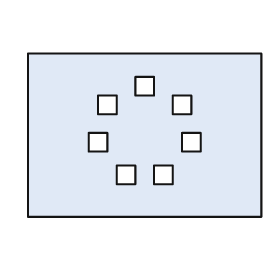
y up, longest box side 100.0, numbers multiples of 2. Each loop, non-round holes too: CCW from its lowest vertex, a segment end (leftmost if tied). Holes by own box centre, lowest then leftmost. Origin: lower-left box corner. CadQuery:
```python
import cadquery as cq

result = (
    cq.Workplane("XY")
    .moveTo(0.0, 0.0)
    .lineTo(100.0, 0.0)
    .lineTo(100.0, 70.0)
    .lineTo(0.0, 70.0)
    .close()
    .moveTo(38.0, 14.0)
    .lineTo(46.0, 14.0)
    .lineTo(46.0, 22.0)
    .lineTo(38.0, 22.0)
    .close()
    .moveTo(54.0, 14.0)
    .lineTo(62.0, 14.0)
    .lineTo(62.0, 22.0)
    .lineTo(54.0, 22.0)
    .close()
    .moveTo(26.0, 28.0)
    .lineTo(34.0, 28.0)
    .lineTo(34.0, 36.0)
    .lineTo(26.0, 36.0)
    .close()
    .moveTo(66.0, 28.0)
    .lineTo(74.0, 28.0)
    .lineTo(74.0, 36.0)
    .lineTo(66.0, 36.0)
    .close()
    .moveTo(30.0, 44.0)
    .lineTo(38.0, 44.0)
    .lineTo(38.0, 52.0)
    .lineTo(30.0, 52.0)
    .close()
    .moveTo(62.0, 44.0)
    .lineTo(70.0, 44.0)
    .lineTo(70.0, 52.0)
    .lineTo(62.0, 52.0)
    .close()
    .moveTo(46.0, 52.0)
    .lineTo(54.0, 52.0)
    .lineTo(54.0, 60.0)
    .lineTo(46.0, 60.0)
    .close()
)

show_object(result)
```